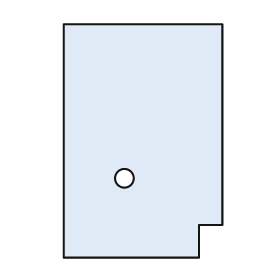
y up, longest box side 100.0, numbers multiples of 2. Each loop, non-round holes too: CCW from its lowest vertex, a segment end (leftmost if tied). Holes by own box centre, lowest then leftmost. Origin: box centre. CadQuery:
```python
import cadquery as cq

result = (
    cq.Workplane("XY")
    .moveTo(-34.0, -50.0)
    .lineTo(24.0, -50.0)
    .lineTo(24.0, -36.0)
    .lineTo(34.0, -36.0)
    .lineTo(34.0, 50.0)
    .lineTo(-34.0, 50.0)
    .close()
    .moveTo(-8.0, -16.0)
    .circle(4.0)
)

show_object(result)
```